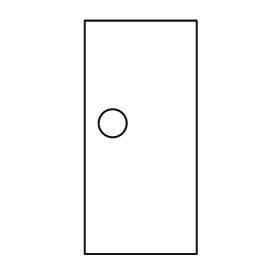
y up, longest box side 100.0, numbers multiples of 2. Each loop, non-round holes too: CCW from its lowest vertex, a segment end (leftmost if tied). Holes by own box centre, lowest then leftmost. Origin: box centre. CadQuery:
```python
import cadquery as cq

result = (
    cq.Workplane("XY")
    .moveTo(-24.0, -50.0)
    .lineTo(24.0, -50.0)
    .lineTo(24.0, 50.0)
    .lineTo(-24.0, 50.0)
    .close()
    .moveTo(-12.0, 6.0)
    .circle(6.0)
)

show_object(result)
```